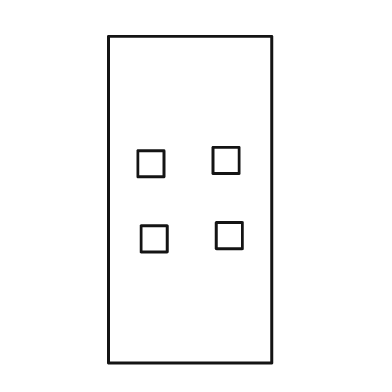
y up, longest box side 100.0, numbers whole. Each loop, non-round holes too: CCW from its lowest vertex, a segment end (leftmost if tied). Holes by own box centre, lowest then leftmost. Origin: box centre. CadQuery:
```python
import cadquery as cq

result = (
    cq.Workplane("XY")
    .moveTo(-25.0, -50.0)
    .lineTo(25.0, -50.0)
    .lineTo(25.0, 50.0)
    .lineTo(-25.0, 50.0)
    .close()
    .moveTo(-15.0, -16.0)
    .lineTo(-7.0, -16.0)
    .lineTo(-7.0, -8.0)
    .lineTo(-15.0, -8.0)
    .close()
    .moveTo(8.0, -15.0)
    .lineTo(16.0, -15.0)
    .lineTo(16.0, -7.0)
    .lineTo(8.0, -7.0)
    .close()
    .moveTo(-16.0, 7.0)
    .lineTo(-8.0, 7.0)
    .lineTo(-8.0, 15.0)
    .lineTo(-16.0, 15.0)
    .close()
    .moveTo(7.0, 8.0)
    .lineTo(15.0, 8.0)
    .lineTo(15.0, 16.0)
    .lineTo(7.0, 16.0)
    .close()
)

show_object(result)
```